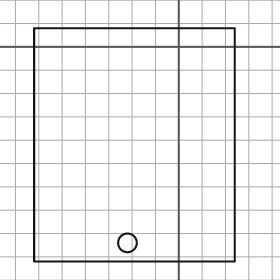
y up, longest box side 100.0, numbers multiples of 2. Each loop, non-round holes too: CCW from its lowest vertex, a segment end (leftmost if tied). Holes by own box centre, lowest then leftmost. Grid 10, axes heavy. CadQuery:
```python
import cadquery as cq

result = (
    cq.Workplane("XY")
    .moveTo(-62.0, -92.0)
    .lineTo(24.0, -92.0)
    .lineTo(24.0, 8.0)
    .lineTo(-62.0, 8.0)
    .close()
    .moveTo(-22.0, -84.0)
    .circle(4.0)
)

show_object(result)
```